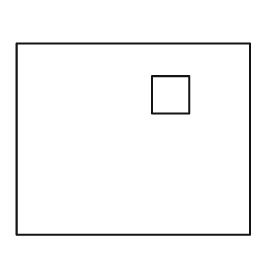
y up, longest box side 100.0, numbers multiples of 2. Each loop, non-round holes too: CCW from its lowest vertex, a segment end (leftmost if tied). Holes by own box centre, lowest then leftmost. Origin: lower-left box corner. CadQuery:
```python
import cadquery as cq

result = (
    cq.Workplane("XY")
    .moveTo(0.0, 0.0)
    .lineTo(100.0, 0.0)
    .lineTo(100.0, 82.0)
    .lineTo(0.0, 82.0)
    .close()
    .moveTo(58.0, 52.0)
    .lineTo(74.0, 52.0)
    .lineTo(74.0, 68.0)
    .lineTo(58.0, 68.0)
    .close()
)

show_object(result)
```